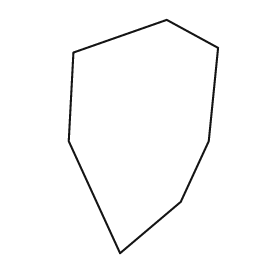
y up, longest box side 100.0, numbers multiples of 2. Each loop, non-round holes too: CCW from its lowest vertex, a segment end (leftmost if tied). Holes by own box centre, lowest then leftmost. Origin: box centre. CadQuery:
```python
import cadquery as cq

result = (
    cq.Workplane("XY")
    .moveTo(-10.0, -50.0)
    .lineTo(16.0, -28.0)
    .lineTo(28.0, -2.0)
    .lineTo(32.0, 38.0)
    .lineTo(10.0, 50.0)
    .lineTo(-30.0, 36.0)
    .lineTo(-32.0, -2.0)
    .close()
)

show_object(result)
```